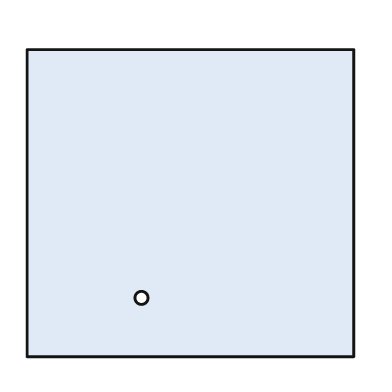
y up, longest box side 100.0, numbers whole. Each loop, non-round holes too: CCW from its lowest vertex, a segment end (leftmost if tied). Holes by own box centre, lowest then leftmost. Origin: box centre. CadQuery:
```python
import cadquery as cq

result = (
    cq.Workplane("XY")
    .moveTo(-50.0, -47.0)
    .lineTo(50.0, -47.0)
    .lineTo(50.0, 47.0)
    .lineTo(-50.0, 47.0)
    .close()
    .moveTo(-15.0, -29.0)
    .circle(2.0)
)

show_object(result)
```